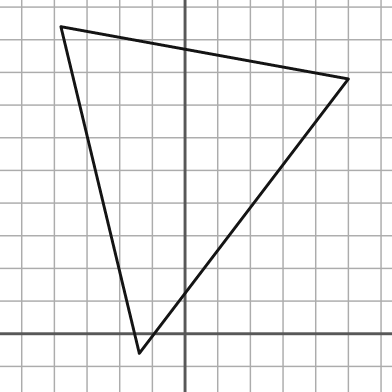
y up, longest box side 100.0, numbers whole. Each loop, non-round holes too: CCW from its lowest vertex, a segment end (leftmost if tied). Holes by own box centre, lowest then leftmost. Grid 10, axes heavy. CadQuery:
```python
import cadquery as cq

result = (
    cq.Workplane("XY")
    .moveTo(-14.0, -6.0)
    .lineTo(50.0, 78.0)
    .lineTo(-38.0, 94.0)
    .close()
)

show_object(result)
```